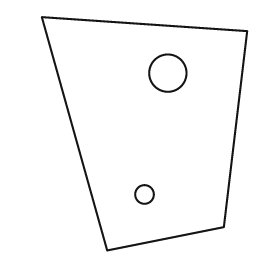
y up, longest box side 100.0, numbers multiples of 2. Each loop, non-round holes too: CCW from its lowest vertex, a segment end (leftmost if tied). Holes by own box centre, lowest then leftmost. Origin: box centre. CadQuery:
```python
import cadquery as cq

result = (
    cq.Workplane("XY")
    .moveTo(-16.0, -50.0)
    .lineTo(34.0, -40.0)
    .lineTo(44.0, 44.0)
    .lineTo(-44.0, 50.0)
    .close()
    .moveTo(0.0, -26.0)
    .circle(4.0)
    .moveTo(10.0, 26.0)
    .circle(8.0)
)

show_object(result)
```